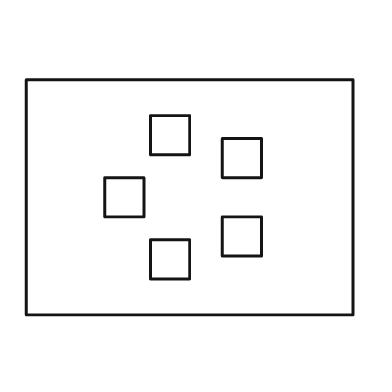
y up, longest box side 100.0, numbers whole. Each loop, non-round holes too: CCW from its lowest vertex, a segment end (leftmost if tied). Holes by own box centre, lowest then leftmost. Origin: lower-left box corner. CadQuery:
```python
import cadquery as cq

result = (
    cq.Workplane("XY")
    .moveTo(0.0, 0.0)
    .lineTo(100.0, 0.0)
    .lineTo(100.0, 72.0)
    .lineTo(0.0, 72.0)
    .close()
    .moveTo(38.0, 11.0)
    .lineTo(50.0, 11.0)
    .lineTo(50.0, 23.0)
    .lineTo(38.0, 23.0)
    .close()
    .moveTo(60.0, 18.0)
    .lineTo(72.0, 18.0)
    .lineTo(72.0, 30.0)
    .lineTo(60.0, 30.0)
    .close()
    .moveTo(24.0, 30.0)
    .lineTo(36.0, 30.0)
    .lineTo(36.0, 42.0)
    .lineTo(24.0, 42.0)
    .close()
    .moveTo(60.0, 42.0)
    .lineTo(72.0, 42.0)
    .lineTo(72.0, 54.0)
    .lineTo(60.0, 54.0)
    .close()
    .moveTo(38.0, 49.0)
    .lineTo(50.0, 49.0)
    .lineTo(50.0, 61.0)
    .lineTo(38.0, 61.0)
    .close()
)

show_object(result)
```